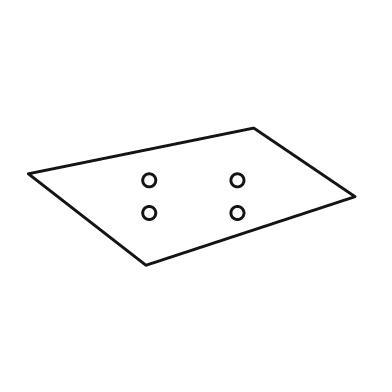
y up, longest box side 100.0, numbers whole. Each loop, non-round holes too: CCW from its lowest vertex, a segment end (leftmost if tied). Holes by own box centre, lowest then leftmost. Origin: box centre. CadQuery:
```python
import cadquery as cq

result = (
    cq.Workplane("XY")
    .moveTo(-14.0, -21.0)
    .lineTo(50.0, 0.0)
    .lineTo(19.0, 21.0)
    .lineTo(-50.0, 7.0)
    .close()
    .moveTo(-13.0, -5.0)
    .circle(2.0)
    .moveTo(14.0, -5.0)
    .circle(2.0)
    .moveTo(-13.0, 5.0)
    .circle(2.0)
    .moveTo(14.0, 5.0)
    .circle(2.0)
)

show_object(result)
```